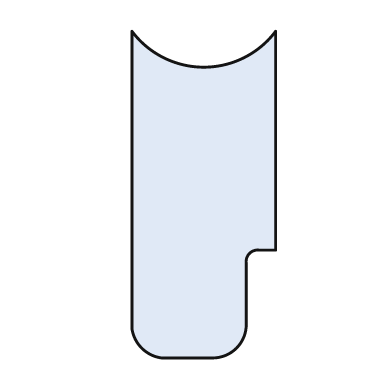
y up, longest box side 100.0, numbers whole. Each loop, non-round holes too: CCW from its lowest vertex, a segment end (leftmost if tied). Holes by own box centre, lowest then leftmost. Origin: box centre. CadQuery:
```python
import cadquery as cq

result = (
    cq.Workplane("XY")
    .moveTo(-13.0, -50.0)
    .lineTo(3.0, -50.0)
    .threePointArc((10.0, -47.0), (13.0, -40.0))
    .lineTo(13.0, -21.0)
    .threePointArc((14.0, -18.0), (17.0, -17.0))
    .lineTo(22.0, -17.0)
    .lineTo(22.0, 50.0)
    .threePointArc((0.0, 39.0), (-22.0, 50.0))
    .lineTo(-22.0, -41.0)
    .threePointArc((-19.0, -47.0), (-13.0, -50.0))
    .close()
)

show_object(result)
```